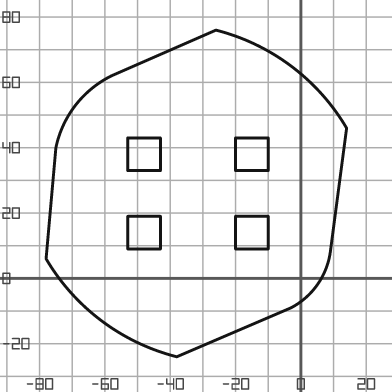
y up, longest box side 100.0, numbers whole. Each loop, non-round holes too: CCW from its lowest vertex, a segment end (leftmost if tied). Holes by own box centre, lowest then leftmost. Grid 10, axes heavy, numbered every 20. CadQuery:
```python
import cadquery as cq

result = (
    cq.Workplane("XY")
    .moveTo(-38.0, -24.0)
    .lineTo(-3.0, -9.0)
    .threePointArc((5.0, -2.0), (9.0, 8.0))
    .lineTo(14.0, 46.0)
    .threePointArc((-3.0, 65.0), (-26.0, 76.0))
    .lineTo(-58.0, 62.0)
    .threePointArc((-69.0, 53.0), (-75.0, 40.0))
    .lineTo(-78.0, 6.0)
    .threePointArc((-61.0, -13.0), (-38.0, -24.0))
    .close()
    .moveTo(-53.0, 9.0)
    .lineTo(-43.0, 9.0)
    .lineTo(-43.0, 19.0)
    .lineTo(-53.0, 19.0)
    .close()
    .moveTo(-20.0, 9.0)
    .lineTo(-10.0, 9.0)
    .lineTo(-10.0, 19.0)
    .lineTo(-20.0, 19.0)
    .close()
    .moveTo(-53.0, 33.0)
    .lineTo(-43.0, 33.0)
    .lineTo(-43.0, 43.0)
    .lineTo(-53.0, 43.0)
    .close()
    .moveTo(-20.0, 33.0)
    .lineTo(-10.0, 33.0)
    .lineTo(-10.0, 43.0)
    .lineTo(-20.0, 43.0)
    .close()
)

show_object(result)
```